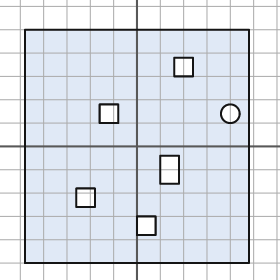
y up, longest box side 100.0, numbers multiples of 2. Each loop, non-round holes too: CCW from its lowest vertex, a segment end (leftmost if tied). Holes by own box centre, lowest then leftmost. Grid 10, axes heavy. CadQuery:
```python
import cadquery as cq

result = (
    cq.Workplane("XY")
    .moveTo(-48.0, -50.0)
    .lineTo(48.0, -50.0)
    .lineTo(48.0, 50.0)
    .lineTo(-48.0, 50.0)
    .close()
    .moveTo(0.0, -38.0)
    .lineTo(8.0, -38.0)
    .lineTo(8.0, -30.0)
    .lineTo(0.0, -30.0)
    .close()
    .moveTo(-26.0, -26.0)
    .lineTo(-18.0, -26.0)
    .lineTo(-18.0, -18.0)
    .lineTo(-26.0, -18.0)
    .close()
    .moveTo(10.0, -16.0)
    .lineTo(18.0, -16.0)
    .lineTo(18.0, -4.0)
    .lineTo(10.0, -4.0)
    .close()
    .moveTo(-16.0, 10.0)
    .lineTo(-8.0, 10.0)
    .lineTo(-8.0, 18.0)
    .lineTo(-16.0, 18.0)
    .close()
    .moveTo(40.0, 14.0)
    .circle(4.0)
    .moveTo(16.0, 30.0)
    .lineTo(24.0, 30.0)
    .lineTo(24.0, 38.0)
    .lineTo(16.0, 38.0)
    .close()
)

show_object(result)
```